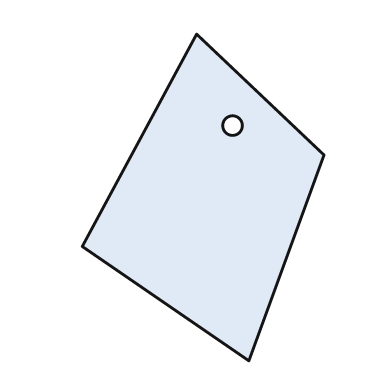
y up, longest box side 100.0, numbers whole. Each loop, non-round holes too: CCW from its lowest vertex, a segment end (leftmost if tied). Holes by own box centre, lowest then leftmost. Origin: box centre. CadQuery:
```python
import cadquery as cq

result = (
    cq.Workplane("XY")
    .moveTo(14.0, -50.0)
    .lineTo(37.0, 13.0)
    .lineTo(-2.0, 50.0)
    .lineTo(-37.0, -15.0)
    .close()
    .moveTo(9.0, 22.0)
    .circle(3.0)
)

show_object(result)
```